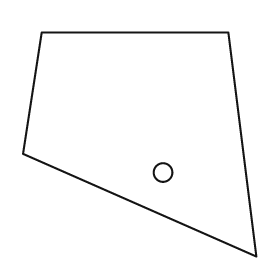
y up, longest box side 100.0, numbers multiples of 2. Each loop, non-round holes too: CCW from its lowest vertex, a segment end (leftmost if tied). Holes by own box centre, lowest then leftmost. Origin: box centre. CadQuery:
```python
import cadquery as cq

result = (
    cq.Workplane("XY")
    .moveTo(50.0, -48.0)
    .lineTo(38.0, 48.0)
    .lineTo(-42.0, 48.0)
    .lineTo(-50.0, -4.0)
    .close()
    .moveTo(10.0, -12.0)
    .circle(4.0)
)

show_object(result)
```